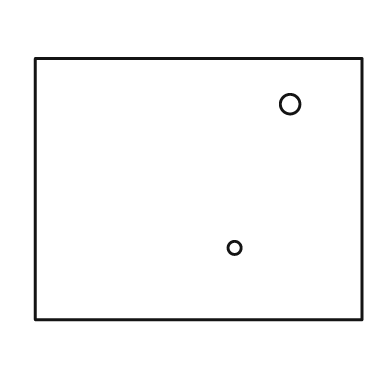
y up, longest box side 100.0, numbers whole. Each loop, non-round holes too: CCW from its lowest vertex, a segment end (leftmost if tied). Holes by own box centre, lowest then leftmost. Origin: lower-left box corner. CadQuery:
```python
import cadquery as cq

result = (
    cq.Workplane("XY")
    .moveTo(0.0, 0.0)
    .lineTo(100.0, 0.0)
    .lineTo(100.0, 80.0)
    .lineTo(0.0, 80.0)
    .close()
    .moveTo(61.0, 22.0)
    .circle(2.0)
    .moveTo(78.0, 66.0)
    .circle(3.0)
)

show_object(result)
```